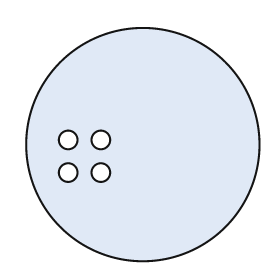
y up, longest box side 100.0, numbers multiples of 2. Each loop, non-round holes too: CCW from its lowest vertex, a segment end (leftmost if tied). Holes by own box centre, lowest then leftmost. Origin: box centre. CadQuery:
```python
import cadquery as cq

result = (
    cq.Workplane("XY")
    .moveTo(0.0, 0.0)
    .circle(50.0)
    .moveTo(-32.0, -12.0)
    .circle(4.0)
    .moveTo(-18.0, -12.0)
    .circle(4.0)
    .moveTo(-32.0, 2.0)
    .circle(4.0)
    .moveTo(-18.0, 2.0)
    .circle(4.0)
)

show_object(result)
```